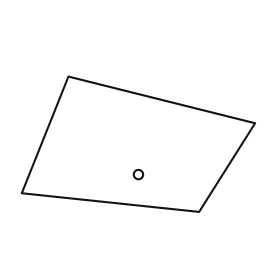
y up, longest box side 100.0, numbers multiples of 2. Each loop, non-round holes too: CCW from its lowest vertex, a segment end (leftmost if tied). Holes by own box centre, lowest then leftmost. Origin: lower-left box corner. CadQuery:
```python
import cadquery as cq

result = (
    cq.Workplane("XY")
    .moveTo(76.0, 0.0)
    .lineTo(100.0, 38.0)
    .lineTo(20.0, 58.0)
    .lineTo(0.0, 8.0)
    .close()
    .moveTo(50.0, 16.0)
    .circle(2.0)
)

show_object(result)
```